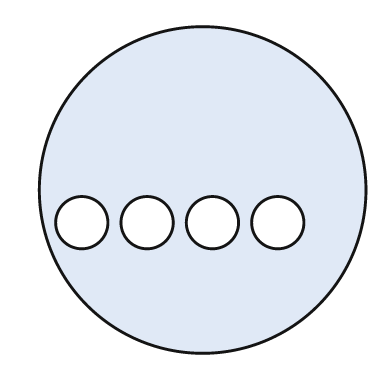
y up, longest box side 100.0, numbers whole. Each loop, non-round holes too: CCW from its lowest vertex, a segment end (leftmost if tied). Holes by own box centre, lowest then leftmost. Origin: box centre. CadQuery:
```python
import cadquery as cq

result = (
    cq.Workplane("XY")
    .moveTo(0.0, 0.0)
    .circle(50.0)
    .moveTo(-37.0, -10.0)
    .circle(8.0)
    .moveTo(-17.0, -10.0)
    .circle(8.0)
    .moveTo(3.0, -10.0)
    .circle(8.0)
    .moveTo(23.0, -10.0)
    .circle(8.0)
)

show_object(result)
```